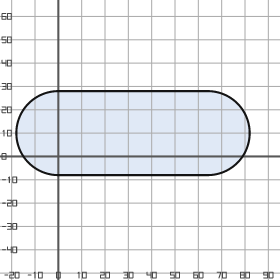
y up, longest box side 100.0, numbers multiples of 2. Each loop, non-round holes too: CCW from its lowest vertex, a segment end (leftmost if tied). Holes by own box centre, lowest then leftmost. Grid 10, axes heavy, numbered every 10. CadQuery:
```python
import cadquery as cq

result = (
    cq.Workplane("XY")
    .moveTo(0.0, -8.0)
    .lineTo(64.0, -8.0)
    .threePointArc((82.0, 10.0), (64.0, 28.0))
    .lineTo(0.0, 28.0)
    .threePointArc((-18.0, 10.0), (0.0, -8.0))
    .close()
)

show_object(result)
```